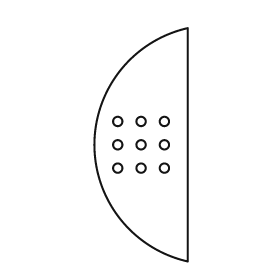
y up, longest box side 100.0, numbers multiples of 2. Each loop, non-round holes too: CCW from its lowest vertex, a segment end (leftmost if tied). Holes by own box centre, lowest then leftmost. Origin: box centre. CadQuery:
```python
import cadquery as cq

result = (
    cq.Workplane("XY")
    .moveTo(20.0, -50.0)
    .lineTo(20.0, 50.0)
    .threePointArc((-20.0, 0.0), (20.0, -50.0))
    .close()
    .moveTo(-10.0, -10.0)
    .circle(2.0)
    .moveTo(0.0, -10.0)
    .circle(2.0)
    .moveTo(10.0, -10.0)
    .circle(2.0)
    .moveTo(-10.0, 0.0)
    .circle(2.0)
    .moveTo(0.0, 0.0)
    .circle(2.0)
    .moveTo(10.0, 0.0)
    .circle(2.0)
    .moveTo(-10.0, 10.0)
    .circle(2.0)
    .moveTo(0.0, 10.0)
    .circle(2.0)
    .moveTo(10.0, 10.0)
    .circle(2.0)
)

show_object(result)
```